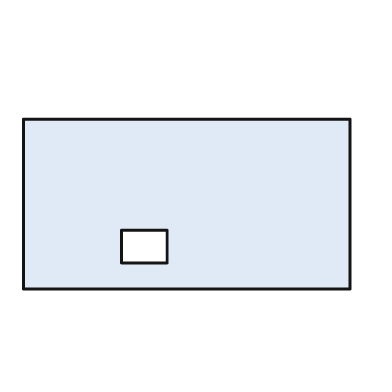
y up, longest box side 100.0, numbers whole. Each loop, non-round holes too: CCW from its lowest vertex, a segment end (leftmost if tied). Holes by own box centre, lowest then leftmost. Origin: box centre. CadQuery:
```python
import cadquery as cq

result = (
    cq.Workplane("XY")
    .moveTo(-50.0, -26.0)
    .lineTo(50.0, -26.0)
    .lineTo(50.0, 26.0)
    .lineTo(-50.0, 26.0)
    .close()
    .moveTo(-20.0, -18.0)
    .lineTo(-6.0, -18.0)
    .lineTo(-6.0, -8.0)
    .lineTo(-20.0, -8.0)
    .close()
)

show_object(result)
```